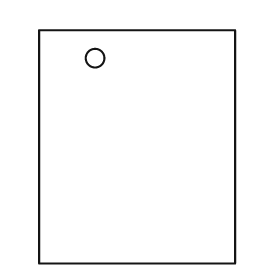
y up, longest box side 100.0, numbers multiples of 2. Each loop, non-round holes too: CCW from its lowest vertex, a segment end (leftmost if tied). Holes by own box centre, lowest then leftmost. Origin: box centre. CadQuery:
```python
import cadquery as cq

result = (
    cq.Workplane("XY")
    .moveTo(-42.0, -50.0)
    .lineTo(42.0, -50.0)
    .lineTo(42.0, 50.0)
    .lineTo(-42.0, 50.0)
    .close()
    .moveTo(-18.0, 38.0)
    .circle(4.0)
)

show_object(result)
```